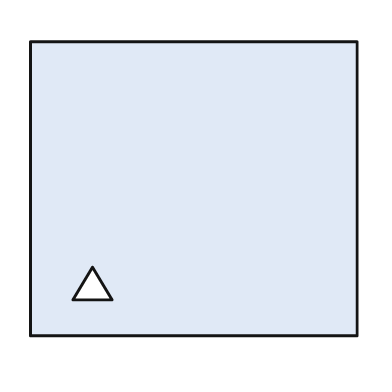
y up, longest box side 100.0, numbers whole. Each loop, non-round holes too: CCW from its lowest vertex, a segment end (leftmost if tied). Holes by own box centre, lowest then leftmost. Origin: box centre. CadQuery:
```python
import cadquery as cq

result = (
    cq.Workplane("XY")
    .moveTo(-50.0, -45.0)
    .lineTo(50.0, -45.0)
    .lineTo(50.0, 45.0)
    .lineTo(-50.0, 45.0)
    .close()
    .moveTo(-37.0, -34.0)
    .lineTo(-25.0, -34.0)
    .lineTo(-31.0, -24.0)
    .close()
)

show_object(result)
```